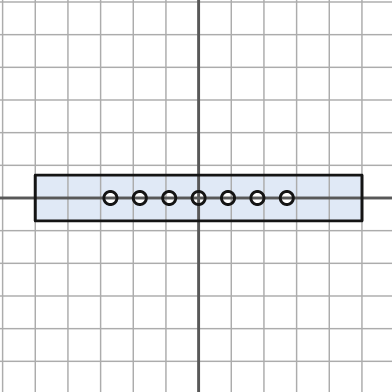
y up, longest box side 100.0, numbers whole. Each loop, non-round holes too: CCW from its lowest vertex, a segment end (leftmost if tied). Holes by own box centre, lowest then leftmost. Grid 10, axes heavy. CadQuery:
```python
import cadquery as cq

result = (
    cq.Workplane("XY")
    .moveTo(-50.0, -7.0)
    .lineTo(50.0, -7.0)
    .lineTo(50.0, 7.0)
    .lineTo(-50.0, 7.0)
    .close()
    .moveTo(-27.0, 0.0)
    .circle(2.0)
    .moveTo(-18.0, 0.0)
    .circle(2.0)
    .moveTo(-9.0, 0.0)
    .circle(2.0)
    .moveTo(0.0, 0.0)
    .circle(2.0)
    .moveTo(9.0, 0.0)
    .circle(2.0)
    .moveTo(18.0, 0.0)
    .circle(2.0)
    .moveTo(27.0, 0.0)
    .circle(2.0)
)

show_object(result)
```